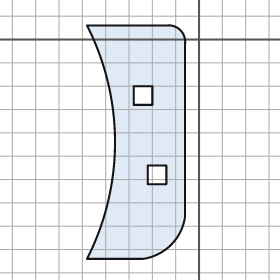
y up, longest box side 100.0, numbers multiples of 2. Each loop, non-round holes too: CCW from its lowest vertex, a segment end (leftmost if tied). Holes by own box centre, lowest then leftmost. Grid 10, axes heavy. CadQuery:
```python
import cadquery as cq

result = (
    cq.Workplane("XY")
    .moveTo(-48.0, -94.0)
    .lineTo(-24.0, -94.0)
    .threePointArc((-12.0, -88.0), (-6.0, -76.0))
    .lineTo(-6.0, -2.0)
    .threePointArc((-8.0, 4.0), (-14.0, 6.0))
    .lineTo(-48.0, 6.0)
    .threePointArc((-36.0, -44.0), (-48.0, -94.0))
    .close()
    .moveTo(-22.0, -62.0)
    .lineTo(-14.0, -62.0)
    .lineTo(-14.0, -54.0)
    .lineTo(-22.0, -54.0)
    .close()
    .moveTo(-28.0, -28.0)
    .lineTo(-20.0, -28.0)
    .lineTo(-20.0, -20.0)
    .lineTo(-28.0, -20.0)
    .close()
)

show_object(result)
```